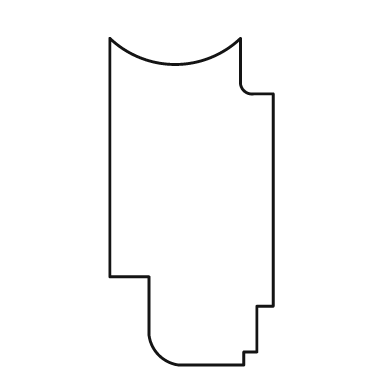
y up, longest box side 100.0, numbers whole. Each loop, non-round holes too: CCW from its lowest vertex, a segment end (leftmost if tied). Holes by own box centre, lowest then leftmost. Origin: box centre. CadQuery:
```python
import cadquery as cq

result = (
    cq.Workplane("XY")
    .moveTo(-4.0, -50.0)
    .lineTo(16.0, -50.0)
    .lineTo(16.0, -46.0)
    .lineTo(20.0, -46.0)
    .lineTo(20.0, -32.0)
    .lineTo(25.0, -32.0)
    .lineTo(25.0, 33.0)
    .lineTo(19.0, 33.0)
    .threePointArc((16.0, 34.0), (15.0, 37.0))
    .lineTo(15.0, 50.0)
    .threePointArc((-5.0, 42.0), (-25.0, 50.0))
    .lineTo(-25.0, -23.0)
    .lineTo(-13.0, -23.0)
    .lineTo(-13.0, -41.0)
    .threePointArc((-10.0, -47.0), (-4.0, -50.0))
    .close()
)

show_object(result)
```